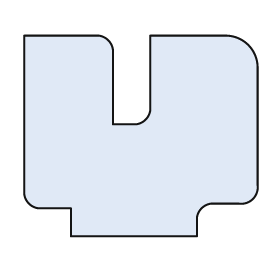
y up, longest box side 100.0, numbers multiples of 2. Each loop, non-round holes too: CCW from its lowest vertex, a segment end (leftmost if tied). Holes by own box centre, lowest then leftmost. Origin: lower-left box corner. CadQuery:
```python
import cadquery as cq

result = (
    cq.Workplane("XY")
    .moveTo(20.0, 0.0)
    .lineTo(74.0, 0.0)
    .lineTo(74.0, 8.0)
    .threePointArc((76.0, 12.0), (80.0, 14.0))
    .lineTo(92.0, 14.0)
    .threePointArc((98.0, 16.0), (100.0, 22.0))
    .lineTo(100.0, 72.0)
    .threePointArc((96.0, 82.0), (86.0, 86.0))
    .lineTo(54.0, 86.0)
    .lineTo(54.0, 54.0)
    .threePointArc((52.0, 50.0), (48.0, 48.0))
    .lineTo(38.0, 48.0)
    .lineTo(38.0, 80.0)
    .threePointArc((36.0, 84.0), (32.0, 86.0))
    .lineTo(0.0, 86.0)
    .lineTo(0.0, 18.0)
    .threePointArc((2.0, 14.0), (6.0, 12.0))
    .lineTo(20.0, 12.0)
    .close()
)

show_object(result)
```